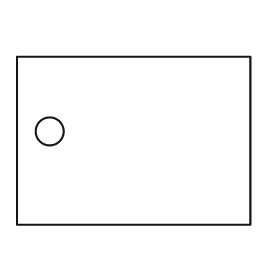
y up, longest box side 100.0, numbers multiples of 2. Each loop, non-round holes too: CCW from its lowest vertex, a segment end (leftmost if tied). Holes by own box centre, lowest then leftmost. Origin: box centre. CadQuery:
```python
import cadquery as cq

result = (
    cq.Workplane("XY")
    .moveTo(-50.0, -36.0)
    .lineTo(50.0, -36.0)
    .lineTo(50.0, 36.0)
    .lineTo(-50.0, 36.0)
    .close()
    .moveTo(-36.0, 4.0)
    .circle(6.0)
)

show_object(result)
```